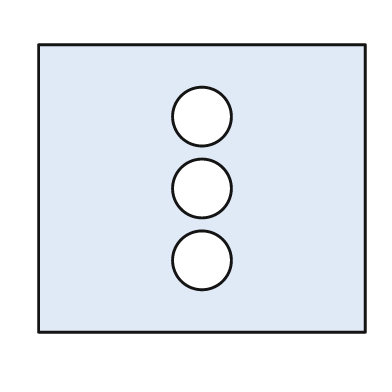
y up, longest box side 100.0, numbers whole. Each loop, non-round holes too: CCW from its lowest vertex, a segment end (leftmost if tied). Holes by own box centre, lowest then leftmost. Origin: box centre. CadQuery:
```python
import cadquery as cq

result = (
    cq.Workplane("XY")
    .moveTo(-50.0, -44.0)
    .lineTo(50.0, -44.0)
    .lineTo(50.0, 44.0)
    .lineTo(-50.0, 44.0)
    .close()
    .moveTo(0.0, -22.0)
    .circle(9.0)
    .moveTo(0.0, 0.0)
    .circle(9.0)
    .moveTo(0.0, 22.0)
    .circle(9.0)
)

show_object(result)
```